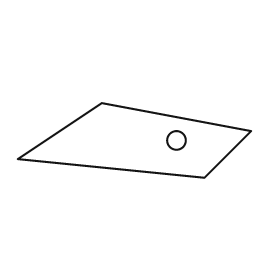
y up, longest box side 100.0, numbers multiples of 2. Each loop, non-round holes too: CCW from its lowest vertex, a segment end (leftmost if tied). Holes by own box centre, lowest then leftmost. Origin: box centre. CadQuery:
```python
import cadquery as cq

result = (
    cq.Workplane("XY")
    .moveTo(30.0, -16.0)
    .lineTo(50.0, 4.0)
    .lineTo(-14.0, 16.0)
    .lineTo(-50.0, -8.0)
    .close()
    .moveTo(18.0, 0.0)
    .circle(4.0)
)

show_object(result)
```